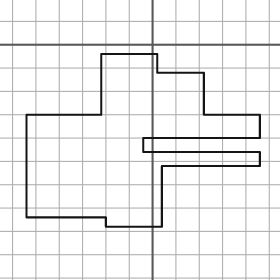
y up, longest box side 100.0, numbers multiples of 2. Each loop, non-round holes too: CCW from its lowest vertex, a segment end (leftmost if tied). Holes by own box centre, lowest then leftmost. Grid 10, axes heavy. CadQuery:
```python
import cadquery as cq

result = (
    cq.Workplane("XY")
    .moveTo(-20.0, -78.0)
    .lineTo(4.0, -78.0)
    .lineTo(4.0, -52.0)
    .lineTo(46.0, -52.0)
    .lineTo(46.0, -46.0)
    .lineTo(-4.0, -46.0)
    .lineTo(-4.0, -40.0)
    .lineTo(46.0, -40.0)
    .lineTo(46.0, -30.0)
    .lineTo(22.0, -30.0)
    .lineTo(22.0, -12.0)
    .lineTo(2.0, -12.0)
    .lineTo(2.0, -4.0)
    .lineTo(-22.0, -4.0)
    .lineTo(-22.0, -30.0)
    .lineTo(-54.0, -30.0)
    .lineTo(-54.0, -74.0)
    .lineTo(-20.0, -74.0)
    .close()
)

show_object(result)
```